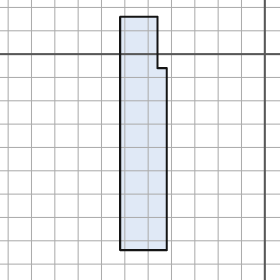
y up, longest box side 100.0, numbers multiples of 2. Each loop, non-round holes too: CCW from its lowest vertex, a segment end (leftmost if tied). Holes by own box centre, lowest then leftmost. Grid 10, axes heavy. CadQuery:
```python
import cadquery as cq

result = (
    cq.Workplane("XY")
    .moveTo(-62.0, -84.0)
    .lineTo(-42.0, -84.0)
    .lineTo(-42.0, -6.0)
    .lineTo(-46.0, -6.0)
    .lineTo(-46.0, 16.0)
    .lineTo(-62.0, 16.0)
    .close()
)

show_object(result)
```